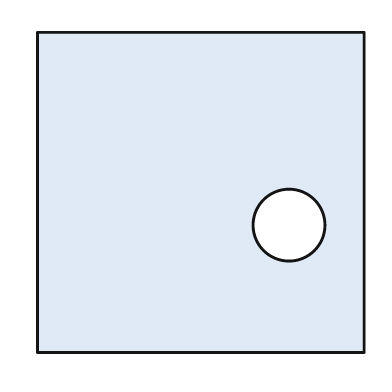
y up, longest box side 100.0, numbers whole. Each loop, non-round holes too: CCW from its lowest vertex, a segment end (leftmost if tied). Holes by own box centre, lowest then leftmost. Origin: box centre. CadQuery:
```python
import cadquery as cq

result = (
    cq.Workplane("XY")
    .moveTo(-50.0, -49.0)
    .lineTo(50.0, -49.0)
    .lineTo(50.0, 49.0)
    .lineTo(-50.0, 49.0)
    .close()
    .moveTo(27.0, -10.0)
    .circle(11.0)
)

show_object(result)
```